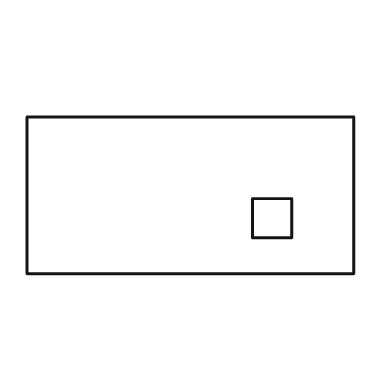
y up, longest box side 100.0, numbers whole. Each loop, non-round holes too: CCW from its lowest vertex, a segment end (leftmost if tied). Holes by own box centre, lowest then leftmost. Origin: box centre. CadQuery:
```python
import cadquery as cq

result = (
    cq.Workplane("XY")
    .moveTo(-50.0, -24.0)
    .lineTo(50.0, -24.0)
    .lineTo(50.0, 24.0)
    .lineTo(-50.0, 24.0)
    .close()
    .moveTo(19.0, -13.0)
    .lineTo(31.0, -13.0)
    .lineTo(31.0, -1.0)
    .lineTo(19.0, -1.0)
    .close()
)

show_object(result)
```